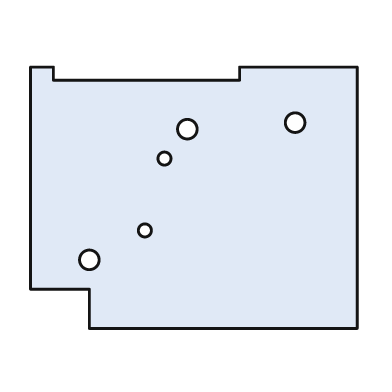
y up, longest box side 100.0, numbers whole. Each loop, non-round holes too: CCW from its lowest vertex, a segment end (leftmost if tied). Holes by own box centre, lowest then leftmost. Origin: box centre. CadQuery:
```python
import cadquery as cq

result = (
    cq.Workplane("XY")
    .moveTo(-32.0, -40.0)
    .lineTo(50.0, -40.0)
    .lineTo(50.0, 40.0)
    .lineTo(14.0, 40.0)
    .lineTo(14.0, 36.0)
    .lineTo(-43.0, 36.0)
    .lineTo(-43.0, 40.0)
    .lineTo(-50.0, 40.0)
    .lineTo(-50.0, -28.0)
    .lineTo(-32.0, -28.0)
    .close()
    .moveTo(-32.0, -19.0)
    .circle(3.0)
    .moveTo(-15.0, -10.0)
    .circle(2.0)
    .moveTo(-9.0, 12.0)
    .circle(2.0)
    .moveTo(-2.0, 21.0)
    .circle(3.0)
    .moveTo(31.0, 23.0)
    .circle(3.0)
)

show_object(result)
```